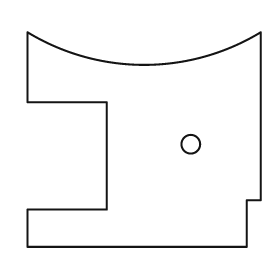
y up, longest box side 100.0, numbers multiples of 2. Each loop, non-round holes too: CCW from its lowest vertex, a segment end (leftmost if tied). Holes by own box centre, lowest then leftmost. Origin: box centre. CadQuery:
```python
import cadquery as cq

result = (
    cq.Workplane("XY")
    .moveTo(-50.0, -46.0)
    .lineTo(44.0, -46.0)
    .lineTo(44.0, -26.0)
    .lineTo(50.0, -26.0)
    .lineTo(50.0, 46.0)
    .threePointArc((0.0, 32.0), (-50.0, 46.0))
    .lineTo(-50.0, 16.0)
    .lineTo(-16.0, 16.0)
    .lineTo(-16.0, -30.0)
    .lineTo(-50.0, -30.0)
    .close()
    .moveTo(20.0, -2.0)
    .circle(4.0)
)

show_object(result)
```